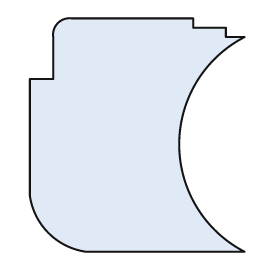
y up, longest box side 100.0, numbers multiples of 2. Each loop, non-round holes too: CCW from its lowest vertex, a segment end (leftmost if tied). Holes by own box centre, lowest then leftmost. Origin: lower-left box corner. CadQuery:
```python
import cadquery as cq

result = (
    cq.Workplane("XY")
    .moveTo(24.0, 0.0)
    .lineTo(92.0, 0.0)
    .threePointArc((64.0, 46.0), (92.0, 92.0))
    .lineTo(84.0, 92.0)
    .lineTo(84.0, 96.0)
    .lineTo(70.0, 96.0)
    .lineTo(70.0, 100.0)
    .lineTo(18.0, 100.0)
    .threePointArc((12.0, 98.0), (10.0, 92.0))
    .lineTo(10.0, 74.0)
    .lineTo(0.0, 74.0)
    .lineTo(0.0, 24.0)
    .threePointArc((8.0, 8.0), (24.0, 0.0))
    .close()
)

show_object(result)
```